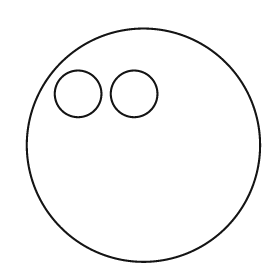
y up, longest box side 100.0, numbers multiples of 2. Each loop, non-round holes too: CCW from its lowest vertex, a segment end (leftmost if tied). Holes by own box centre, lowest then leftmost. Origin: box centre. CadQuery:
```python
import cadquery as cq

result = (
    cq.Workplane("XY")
    .moveTo(0.0, 0.0)
    .circle(50.0)
    .moveTo(-28.0, 22.0)
    .circle(10.0)
    .moveTo(-4.0, 22.0)
    .circle(10.0)
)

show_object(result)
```